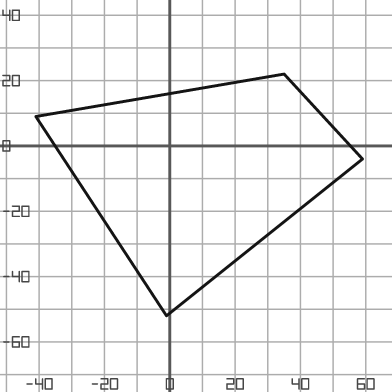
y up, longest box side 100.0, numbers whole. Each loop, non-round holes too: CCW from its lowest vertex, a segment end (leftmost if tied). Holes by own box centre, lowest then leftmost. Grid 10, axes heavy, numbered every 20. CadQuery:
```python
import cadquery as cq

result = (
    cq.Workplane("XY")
    .moveTo(-1.0, -52.0)
    .lineTo(59.0, -4.0)
    .lineTo(35.0, 22.0)
    .lineTo(-41.0, 9.0)
    .close()
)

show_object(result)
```